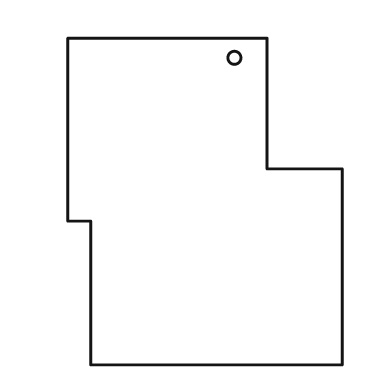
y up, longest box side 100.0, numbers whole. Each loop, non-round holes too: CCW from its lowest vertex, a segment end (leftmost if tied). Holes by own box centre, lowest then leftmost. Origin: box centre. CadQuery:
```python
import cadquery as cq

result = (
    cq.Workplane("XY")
    .moveTo(-35.0, -50.0)
    .lineTo(42.0, -50.0)
    .lineTo(42.0, 10.0)
    .lineTo(19.0, 10.0)
    .lineTo(19.0, 50.0)
    .lineTo(-42.0, 50.0)
    .lineTo(-42.0, -6.0)
    .lineTo(-35.0, -6.0)
    .close()
    .moveTo(9.0, 44.0)
    .circle(2.0)
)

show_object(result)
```